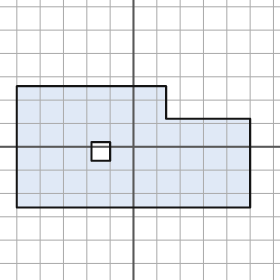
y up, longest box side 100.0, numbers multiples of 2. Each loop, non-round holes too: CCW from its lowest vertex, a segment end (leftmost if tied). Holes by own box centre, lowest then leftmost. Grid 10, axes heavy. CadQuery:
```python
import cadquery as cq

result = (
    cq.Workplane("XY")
    .moveTo(-50.0, -26.0)
    .lineTo(50.0, -26.0)
    .lineTo(50.0, 12.0)
    .lineTo(14.0, 12.0)
    .lineTo(14.0, 26.0)
    .lineTo(-50.0, 26.0)
    .close()
    .moveTo(-18.0, -6.0)
    .lineTo(-10.0, -6.0)
    .lineTo(-10.0, 2.0)
    .lineTo(-18.0, 2.0)
    .close()
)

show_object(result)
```